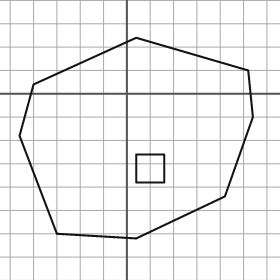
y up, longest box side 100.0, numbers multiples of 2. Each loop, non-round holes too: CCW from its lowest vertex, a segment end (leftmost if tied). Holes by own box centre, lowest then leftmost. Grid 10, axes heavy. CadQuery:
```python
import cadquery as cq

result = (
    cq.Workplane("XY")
    .moveTo(4.0, -62.0)
    .lineTo(42.0, -44.0)
    .lineTo(54.0, -10.0)
    .lineTo(52.0, 10.0)
    .lineTo(4.0, 24.0)
    .lineTo(-40.0, 4.0)
    .lineTo(-46.0, -18.0)
    .lineTo(-30.0, -60.0)
    .close()
    .moveTo(4.0, -38.0)
    .lineTo(16.0, -38.0)
    .lineTo(16.0, -26.0)
    .lineTo(4.0, -26.0)
    .close()
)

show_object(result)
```